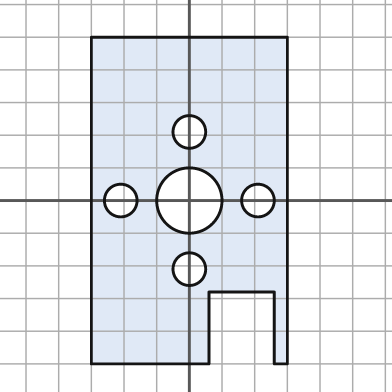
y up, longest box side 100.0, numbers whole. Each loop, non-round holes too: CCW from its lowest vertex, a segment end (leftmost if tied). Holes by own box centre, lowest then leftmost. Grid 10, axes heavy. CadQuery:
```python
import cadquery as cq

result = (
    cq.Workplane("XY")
    .moveTo(-30.0, -50.0)
    .lineTo(6.0, -50.0)
    .lineTo(6.0, -28.0)
    .lineTo(26.0, -28.0)
    .lineTo(26.0, -50.0)
    .lineTo(30.0, -50.0)
    .lineTo(30.0, 50.0)
    .lineTo(-30.0, 50.0)
    .close()
    .moveTo(0.0, -21.0)
    .circle(5.0)
    .moveTo(-21.0, 0.0)
    .circle(5.0)
    .moveTo(0.0, 0.0)
    .circle(10.0)
    .moveTo(21.0, 0.0)
    .circle(5.0)
    .moveTo(0.0, 21.0)
    .circle(5.0)
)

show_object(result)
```